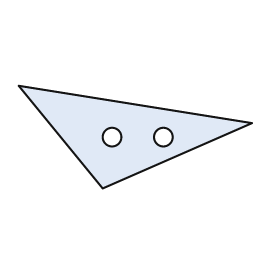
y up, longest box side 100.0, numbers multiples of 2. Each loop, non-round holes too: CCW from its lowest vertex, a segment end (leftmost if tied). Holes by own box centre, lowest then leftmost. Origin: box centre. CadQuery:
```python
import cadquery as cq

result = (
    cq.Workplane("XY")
    .moveTo(-14.0, -22.0)
    .lineTo(50.0, 6.0)
    .lineTo(-50.0, 22.0)
    .close()
    .moveTo(-10.0, 0.0)
    .circle(4.0)
    .moveTo(12.0, 0.0)
    .circle(4.0)
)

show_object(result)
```